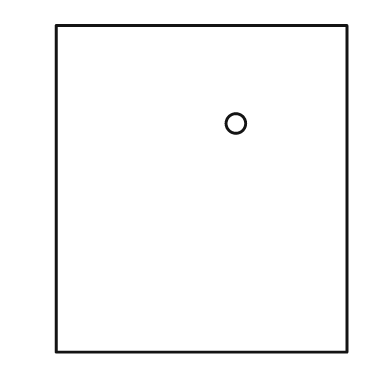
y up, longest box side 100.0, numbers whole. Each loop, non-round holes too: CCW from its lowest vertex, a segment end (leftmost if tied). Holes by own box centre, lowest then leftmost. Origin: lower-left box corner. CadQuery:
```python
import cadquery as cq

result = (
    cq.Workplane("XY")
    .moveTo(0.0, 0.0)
    .lineTo(89.0, 0.0)
    .lineTo(89.0, 100.0)
    .lineTo(0.0, 100.0)
    .close()
    .moveTo(55.0, 70.0)
    .circle(3.0)
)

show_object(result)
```